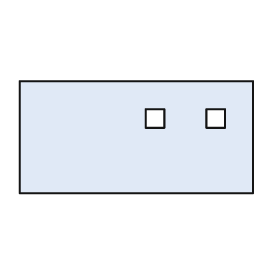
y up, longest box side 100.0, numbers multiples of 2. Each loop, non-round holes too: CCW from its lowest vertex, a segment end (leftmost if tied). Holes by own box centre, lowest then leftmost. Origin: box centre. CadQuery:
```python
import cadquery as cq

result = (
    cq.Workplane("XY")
    .moveTo(-50.0, -24.0)
    .lineTo(50.0, -24.0)
    .lineTo(50.0, 24.0)
    .lineTo(-50.0, 24.0)
    .close()
    .moveTo(4.0, 4.0)
    .lineTo(12.0, 4.0)
    .lineTo(12.0, 12.0)
    .lineTo(4.0, 12.0)
    .close()
    .moveTo(30.0, 4.0)
    .lineTo(38.0, 4.0)
    .lineTo(38.0, 12.0)
    .lineTo(30.0, 12.0)
    .close()
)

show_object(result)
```